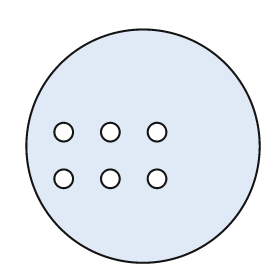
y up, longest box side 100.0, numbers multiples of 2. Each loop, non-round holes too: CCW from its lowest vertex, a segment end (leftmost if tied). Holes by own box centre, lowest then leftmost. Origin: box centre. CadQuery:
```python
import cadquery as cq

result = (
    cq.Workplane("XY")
    .moveTo(0.0, 0.0)
    .circle(50.0)
    .moveTo(-34.0, -14.0)
    .circle(4.0)
    .moveTo(-14.0, -14.0)
    .circle(4.0)
    .moveTo(6.0, -14.0)
    .circle(4.0)
    .moveTo(-34.0, 6.0)
    .circle(4.0)
    .moveTo(-14.0, 6.0)
    .circle(4.0)
    .moveTo(6.0, 6.0)
    .circle(4.0)
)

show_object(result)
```